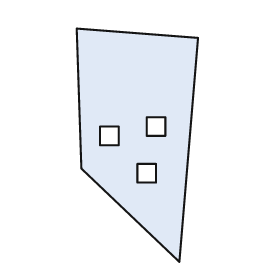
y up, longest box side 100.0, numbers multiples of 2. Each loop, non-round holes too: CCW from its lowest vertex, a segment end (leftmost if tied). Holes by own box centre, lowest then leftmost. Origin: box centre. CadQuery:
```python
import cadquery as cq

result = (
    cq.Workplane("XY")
    .moveTo(18.0, -50.0)
    .lineTo(26.0, 46.0)
    .lineTo(-26.0, 50.0)
    .lineTo(-24.0, -10.0)
    .close()
    .moveTo(0.0, -16.0)
    .lineTo(8.0, -16.0)
    .lineTo(8.0, -8.0)
    .lineTo(0.0, -8.0)
    .close()
    .moveTo(-16.0, 0.0)
    .lineTo(-8.0, 0.0)
    .lineTo(-8.0, 8.0)
    .lineTo(-16.0, 8.0)
    .close()
    .moveTo(4.0, 4.0)
    .lineTo(12.0, 4.0)
    .lineTo(12.0, 12.0)
    .lineTo(4.0, 12.0)
    .close()
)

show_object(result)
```